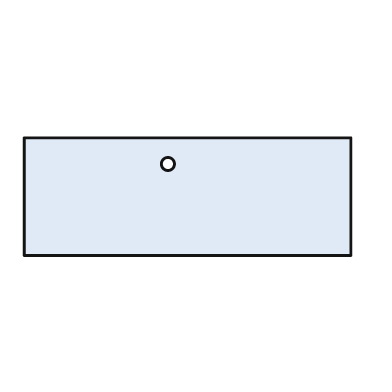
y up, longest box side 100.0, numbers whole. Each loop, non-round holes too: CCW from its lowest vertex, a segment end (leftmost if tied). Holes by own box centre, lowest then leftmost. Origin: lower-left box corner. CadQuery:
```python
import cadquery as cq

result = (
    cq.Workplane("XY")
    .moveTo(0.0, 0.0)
    .lineTo(100.0, 0.0)
    .lineTo(100.0, 36.0)
    .lineTo(0.0, 36.0)
    .close()
    .moveTo(44.0, 28.0)
    .circle(2.0)
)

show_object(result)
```